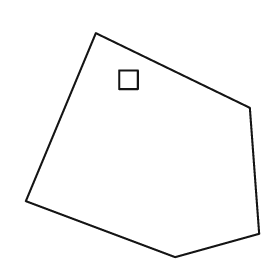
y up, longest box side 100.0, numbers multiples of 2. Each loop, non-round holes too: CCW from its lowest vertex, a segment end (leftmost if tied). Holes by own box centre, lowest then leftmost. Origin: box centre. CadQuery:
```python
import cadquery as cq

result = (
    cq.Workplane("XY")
    .moveTo(14.0, -48.0)
    .lineTo(50.0, -38.0)
    .lineTo(46.0, 16.0)
    .lineTo(-20.0, 48.0)
    .lineTo(-50.0, -24.0)
    .close()
    .moveTo(-10.0, 24.0)
    .lineTo(-2.0, 24.0)
    .lineTo(-2.0, 32.0)
    .lineTo(-10.0, 32.0)
    .close()
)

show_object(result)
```